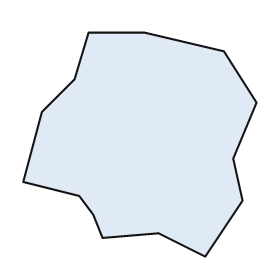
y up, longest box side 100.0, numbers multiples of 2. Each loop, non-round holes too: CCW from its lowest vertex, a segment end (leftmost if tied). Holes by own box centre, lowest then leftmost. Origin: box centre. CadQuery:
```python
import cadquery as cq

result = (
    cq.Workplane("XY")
    .moveTo(28.0, -48.0)
    .lineTo(44.0, -24.0)
    .lineTo(40.0, -6.0)
    .lineTo(50.0, 18.0)
    .lineTo(36.0, 40.0)
    .lineTo(2.0, 48.0)
    .lineTo(-22.0, 48.0)
    .lineTo(-28.0, 28.0)
    .lineTo(-42.0, 14.0)
    .lineTo(-50.0, -16.0)
    .lineTo(-26.0, -22.0)
    .lineTo(-20.0, -30.0)
    .lineTo(-16.0, -40.0)
    .lineTo(8.0, -38.0)
    .close()
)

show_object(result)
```